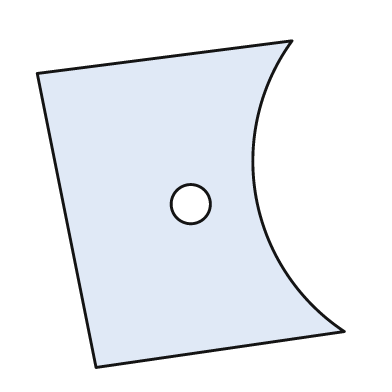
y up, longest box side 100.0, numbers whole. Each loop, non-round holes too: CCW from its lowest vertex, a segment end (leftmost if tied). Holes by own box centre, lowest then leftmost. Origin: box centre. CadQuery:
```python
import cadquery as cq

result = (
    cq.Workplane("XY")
    .moveTo(-29.0, -50.0)
    .lineTo(47.0, -39.0)
    .threePointArc((20.0, 2.0), (31.0, 50.0))
    .lineTo(-47.0, 40.0)
    .close()
    .moveTo(0.0, 0.0)
    .circle(6.0)
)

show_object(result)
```